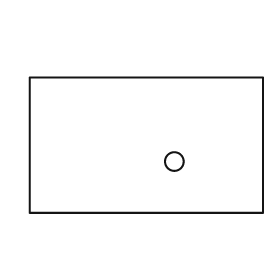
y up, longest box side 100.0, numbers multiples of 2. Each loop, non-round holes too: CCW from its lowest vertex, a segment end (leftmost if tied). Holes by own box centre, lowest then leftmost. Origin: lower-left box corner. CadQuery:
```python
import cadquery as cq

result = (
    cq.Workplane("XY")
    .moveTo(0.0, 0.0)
    .lineTo(100.0, 0.0)
    .lineTo(100.0, 58.0)
    .lineTo(0.0, 58.0)
    .close()
    .moveTo(62.0, 22.0)
    .circle(4.0)
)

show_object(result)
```